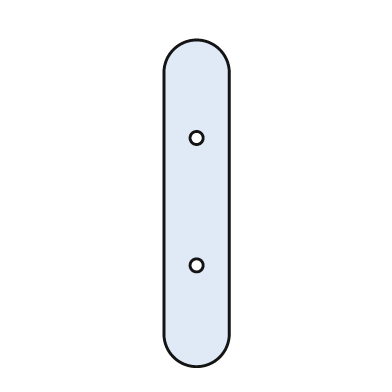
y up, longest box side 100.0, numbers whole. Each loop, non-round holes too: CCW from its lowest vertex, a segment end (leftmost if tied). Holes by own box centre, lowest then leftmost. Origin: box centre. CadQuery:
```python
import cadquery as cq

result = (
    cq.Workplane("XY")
    .moveTo(-10.0, -40.0)
    .threePointArc((0.0, -50.0), (10.0, -40.0))
    .lineTo(10.0, 40.0)
    .threePointArc((0.0, 50.0), (-10.0, 40.0))
    .close()
    .moveTo(0.0, -19.0)
    .circle(2.0)
    .moveTo(0.0, 20.0)
    .circle(2.0)
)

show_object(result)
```